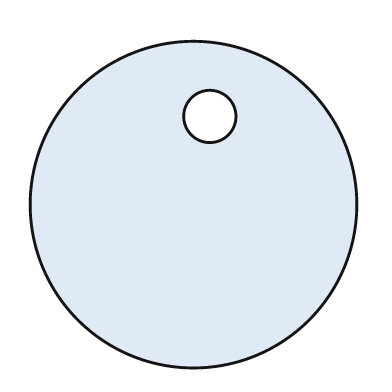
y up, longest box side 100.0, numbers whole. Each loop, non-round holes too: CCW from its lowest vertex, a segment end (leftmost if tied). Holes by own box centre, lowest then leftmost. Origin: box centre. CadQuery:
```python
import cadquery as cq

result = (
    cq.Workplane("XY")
    .moveTo(0.0, 0.0)
    .circle(50.0)
    .moveTo(5.0, 27.0)
    .circle(8.0)
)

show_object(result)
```